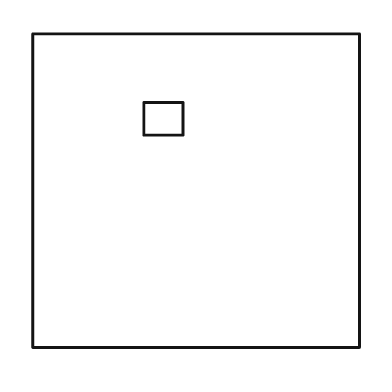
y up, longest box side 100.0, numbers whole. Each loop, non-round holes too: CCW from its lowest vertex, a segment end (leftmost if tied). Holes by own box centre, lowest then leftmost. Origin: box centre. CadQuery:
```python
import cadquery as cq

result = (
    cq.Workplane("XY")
    .moveTo(-50.0, -48.0)
    .lineTo(50.0, -48.0)
    .lineTo(50.0, 48.0)
    .lineTo(-50.0, 48.0)
    .close()
    .moveTo(-16.0, 17.0)
    .lineTo(-4.0, 17.0)
    .lineTo(-4.0, 27.0)
    .lineTo(-16.0, 27.0)
    .close()
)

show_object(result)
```